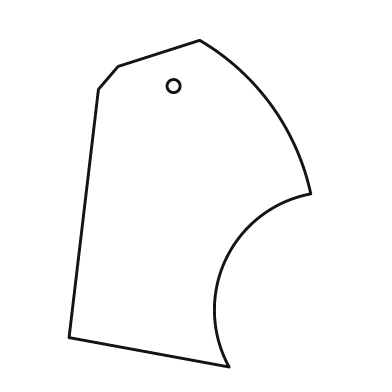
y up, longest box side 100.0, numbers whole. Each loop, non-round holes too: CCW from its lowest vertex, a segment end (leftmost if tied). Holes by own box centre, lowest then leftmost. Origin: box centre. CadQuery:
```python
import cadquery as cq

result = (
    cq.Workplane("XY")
    .moveTo(12.0, -50.0)
    .threePointArc((11.0, -17.0), (37.0, 3.0))
    .threePointArc((25.0, 30.0), (3.0, 50.0))
    .lineTo(-22.0, 42.0)
    .lineTo(-28.0, 35.0)
    .lineTo(-37.0, -41.0)
    .close()
    .moveTo(-5.0, 36.0)
    .circle(2.0)
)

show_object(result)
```